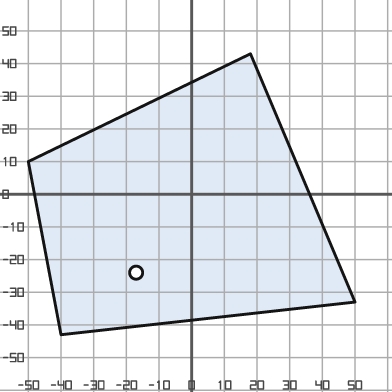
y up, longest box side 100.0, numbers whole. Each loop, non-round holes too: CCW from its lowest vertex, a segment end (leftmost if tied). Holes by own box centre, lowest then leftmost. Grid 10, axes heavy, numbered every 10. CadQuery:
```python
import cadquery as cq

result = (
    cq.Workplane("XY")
    .moveTo(-40.0, -43.0)
    .lineTo(50.0, -33.0)
    .lineTo(18.0, 43.0)
    .lineTo(-50.0, 10.0)
    .close()
    .moveTo(-17.0, -24.0)
    .circle(2.0)
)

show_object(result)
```